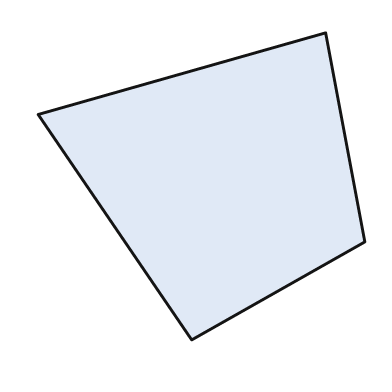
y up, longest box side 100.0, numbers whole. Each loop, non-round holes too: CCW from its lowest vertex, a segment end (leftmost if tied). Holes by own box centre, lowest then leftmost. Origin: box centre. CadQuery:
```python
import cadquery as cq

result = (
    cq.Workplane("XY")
    .moveTo(-3.0, -47.0)
    .lineTo(50.0, -17.0)
    .lineTo(38.0, 47.0)
    .lineTo(-50.0, 22.0)
    .close()
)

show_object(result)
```